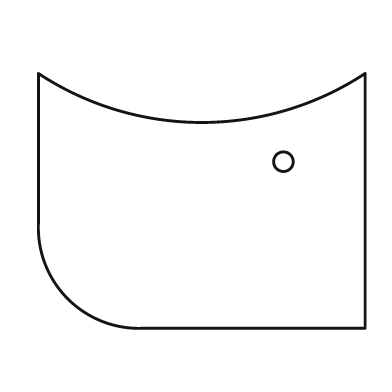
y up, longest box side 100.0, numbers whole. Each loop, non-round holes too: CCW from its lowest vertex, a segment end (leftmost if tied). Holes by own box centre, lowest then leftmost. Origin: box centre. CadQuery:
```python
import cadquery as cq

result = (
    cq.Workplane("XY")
    .moveTo(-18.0, -39.0)
    .lineTo(50.0, -39.0)
    .lineTo(50.0, 39.0)
    .threePointArc((0.0, 24.0), (-50.0, 39.0))
    .lineTo(-50.0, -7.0)
    .threePointArc((-41.0, -30.0), (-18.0, -39.0))
    .close()
    .moveTo(25.0, 12.0)
    .circle(3.0)
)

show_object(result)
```